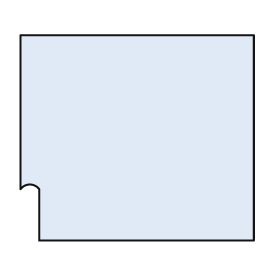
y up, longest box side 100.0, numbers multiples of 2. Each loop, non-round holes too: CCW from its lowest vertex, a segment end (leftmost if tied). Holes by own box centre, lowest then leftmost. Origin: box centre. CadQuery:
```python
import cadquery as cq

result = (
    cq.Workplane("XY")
    .moveTo(-42.0, -44.0)
    .lineTo(50.0, -44.0)
    .lineTo(50.0, 44.0)
    .lineTo(-50.0, 44.0)
    .lineTo(-50.0, -22.0)
    .threePointArc((-46.0, -20.0), (-42.0, -22.0))
    .close()
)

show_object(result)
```